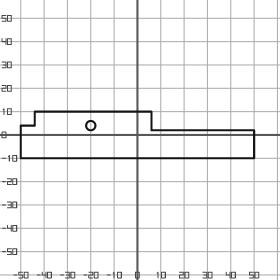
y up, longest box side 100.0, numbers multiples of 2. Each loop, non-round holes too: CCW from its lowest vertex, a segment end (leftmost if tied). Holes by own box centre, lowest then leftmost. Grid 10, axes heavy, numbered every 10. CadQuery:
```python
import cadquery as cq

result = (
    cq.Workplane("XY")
    .moveTo(-50.0, -10.0)
    .lineTo(50.0, -10.0)
    .lineTo(50.0, 2.0)
    .lineTo(6.0, 2.0)
    .lineTo(6.0, 10.0)
    .lineTo(-44.0, 10.0)
    .lineTo(-44.0, 4.0)
    .lineTo(-50.0, 4.0)
    .close()
    .moveTo(-20.0, 4.0)
    .circle(2.0)
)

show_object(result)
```